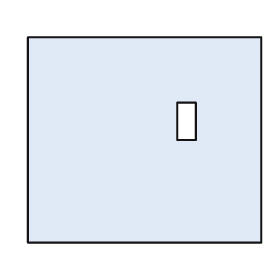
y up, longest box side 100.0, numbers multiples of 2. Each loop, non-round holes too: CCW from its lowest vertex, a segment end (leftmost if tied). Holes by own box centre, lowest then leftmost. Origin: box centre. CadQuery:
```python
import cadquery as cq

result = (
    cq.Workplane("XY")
    .moveTo(-50.0, -44.0)
    .lineTo(50.0, -44.0)
    .lineTo(50.0, 44.0)
    .lineTo(-50.0, 44.0)
    .close()
    .moveTo(14.0, 0.0)
    .lineTo(22.0, 0.0)
    .lineTo(22.0, 16.0)
    .lineTo(14.0, 16.0)
    .close()
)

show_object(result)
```